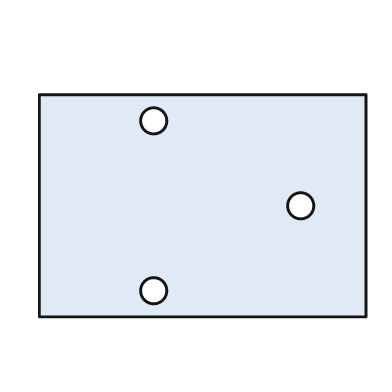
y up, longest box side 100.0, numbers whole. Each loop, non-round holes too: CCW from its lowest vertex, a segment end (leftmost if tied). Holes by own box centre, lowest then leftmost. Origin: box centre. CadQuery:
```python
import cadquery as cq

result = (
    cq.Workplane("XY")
    .moveTo(-50.0, -34.0)
    .lineTo(50.0, -34.0)
    .lineTo(50.0, 34.0)
    .lineTo(-50.0, 34.0)
    .close()
    .moveTo(-15.0, -26.0)
    .circle(4.0)
    .moveTo(30.0, 0.0)
    .circle(4.0)
    .moveTo(-15.0, 26.0)
    .circle(4.0)
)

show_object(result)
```